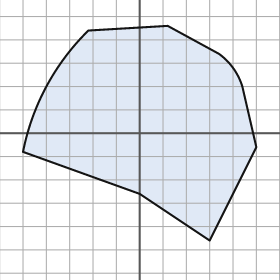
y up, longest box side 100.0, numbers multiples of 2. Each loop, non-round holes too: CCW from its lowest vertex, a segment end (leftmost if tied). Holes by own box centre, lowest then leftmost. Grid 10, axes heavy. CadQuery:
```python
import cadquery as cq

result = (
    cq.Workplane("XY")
    .moveTo(30.0, -46.0)
    .lineTo(50.0, -6.0)
    .lineTo(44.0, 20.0)
    .threePointArc((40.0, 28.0), (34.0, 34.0))
    .lineTo(12.0, 46.0)
    .lineTo(-22.0, 44.0)
    .threePointArc((-40.0, 20.0), (-50.0, -8.0))
    .lineTo(0.0, -26.0)
    .close()
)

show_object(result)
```